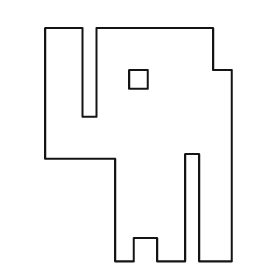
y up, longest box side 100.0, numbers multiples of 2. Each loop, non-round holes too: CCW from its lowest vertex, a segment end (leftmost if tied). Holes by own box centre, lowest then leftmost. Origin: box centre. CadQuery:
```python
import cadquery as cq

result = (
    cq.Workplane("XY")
    .moveTo(-10.0, -50.0)
    .lineTo(-2.0, -50.0)
    .lineTo(-2.0, -40.0)
    .lineTo(8.0, -40.0)
    .lineTo(8.0, -50.0)
    .lineTo(20.0, -50.0)
    .lineTo(20.0, -4.0)
    .lineTo(26.0, -4.0)
    .lineTo(26.0, -50.0)
    .lineTo(40.0, -50.0)
    .lineTo(40.0, 32.0)
    .lineTo(32.0, 32.0)
    .lineTo(32.0, 50.0)
    .lineTo(-18.0, 50.0)
    .lineTo(-18.0, 12.0)
    .lineTo(-24.0, 12.0)
    .lineTo(-24.0, 50.0)
    .lineTo(-40.0, 50.0)
    .lineTo(-40.0, -6.0)
    .lineTo(-10.0, -6.0)
    .close()
    .moveTo(-4.0, 24.0)
    .lineTo(4.0, 24.0)
    .lineTo(4.0, 32.0)
    .lineTo(-4.0, 32.0)
    .close()
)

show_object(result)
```